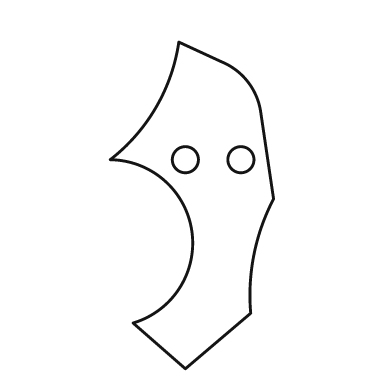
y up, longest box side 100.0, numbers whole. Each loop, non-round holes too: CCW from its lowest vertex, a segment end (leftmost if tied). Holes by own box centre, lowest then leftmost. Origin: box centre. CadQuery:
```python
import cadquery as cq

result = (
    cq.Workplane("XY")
    .moveTo(-2.0, -50.0)
    .lineTo(18.0, -33.0)
    .threePointArc((19.0, -15.0), (25.0, 2.0))
    .lineTo(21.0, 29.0)
    .threePointArc((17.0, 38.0), (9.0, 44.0))
    .lineTo(-4.0, 50.0)
    .threePointArc((-11.0, 30.0), (-25.0, 14.0))
    .threePointArc((0.0, -8.0), (-18.0, -36.0))
    .close()
    .moveTo(-2.0, 14.0)
    .circle(4.0)
    .moveTo(15.0, 14.0)
    .circle(4.0)
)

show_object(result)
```